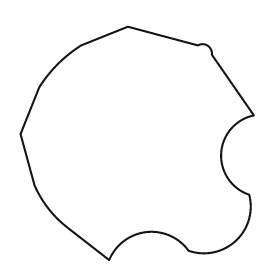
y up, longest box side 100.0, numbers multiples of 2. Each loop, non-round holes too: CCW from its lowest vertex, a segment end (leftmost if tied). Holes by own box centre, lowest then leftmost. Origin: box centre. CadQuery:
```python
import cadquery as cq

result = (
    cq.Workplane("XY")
    .moveTo(-12.0, -50.0)
    .threePointArc((4.0, -38.0), (22.0, -46.0))
    .threePointArc((42.0, -42.0), (48.0, -22.0))
    .threePointArc((36.0, -4.0), (50.0, 12.0))
    .lineTo(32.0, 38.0)
    .threePointArc((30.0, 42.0), (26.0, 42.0))
    .lineTo(-4.0, 50.0)
    .lineTo(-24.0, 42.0)
    .threePointArc((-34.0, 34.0), (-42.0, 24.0))
    .lineTo(-50.0, 4.0)
    .lineTo(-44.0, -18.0)
    .threePointArc((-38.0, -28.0), (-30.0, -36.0))
    .close()
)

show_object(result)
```